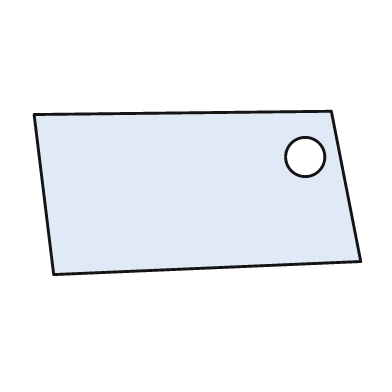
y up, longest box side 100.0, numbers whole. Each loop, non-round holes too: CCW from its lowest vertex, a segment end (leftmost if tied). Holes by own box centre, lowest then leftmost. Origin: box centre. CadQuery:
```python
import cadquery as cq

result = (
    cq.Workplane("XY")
    .moveTo(-44.0, -25.0)
    .lineTo(50.0, -21.0)
    .lineTo(41.0, 25.0)
    .lineTo(-50.0, 24.0)
    .close()
    .moveTo(33.0, 11.0)
    .circle(6.0)
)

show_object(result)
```